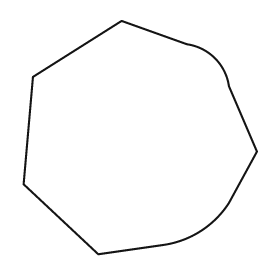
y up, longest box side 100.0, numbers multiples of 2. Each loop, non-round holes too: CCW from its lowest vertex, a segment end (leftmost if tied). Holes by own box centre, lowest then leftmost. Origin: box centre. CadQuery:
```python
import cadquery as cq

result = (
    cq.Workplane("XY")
    .moveTo(-18.0, -50.0)
    .lineTo(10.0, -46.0)
    .threePointArc((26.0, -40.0), (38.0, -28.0))
    .lineTo(50.0, -6.0)
    .lineTo(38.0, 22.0)
    .threePointArc((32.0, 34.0), (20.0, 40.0))
    .lineTo(-8.0, 50.0)
    .lineTo(-46.0, 26.0)
    .lineTo(-50.0, -20.0)
    .close()
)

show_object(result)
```